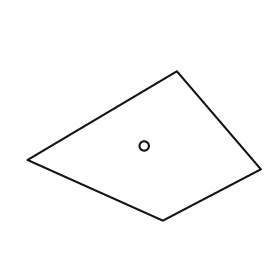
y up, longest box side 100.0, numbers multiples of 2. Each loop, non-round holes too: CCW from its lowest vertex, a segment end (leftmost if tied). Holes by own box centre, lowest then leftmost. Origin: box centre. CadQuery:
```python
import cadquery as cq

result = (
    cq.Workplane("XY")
    .moveTo(8.0, -32.0)
    .lineTo(50.0, -10.0)
    .lineTo(14.0, 32.0)
    .lineTo(-50.0, -6.0)
    .close()
    .moveTo(0.0, 0.0)
    .circle(2.0)
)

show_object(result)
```